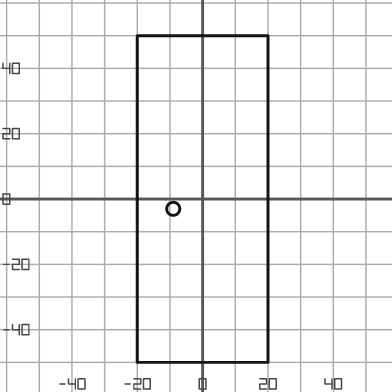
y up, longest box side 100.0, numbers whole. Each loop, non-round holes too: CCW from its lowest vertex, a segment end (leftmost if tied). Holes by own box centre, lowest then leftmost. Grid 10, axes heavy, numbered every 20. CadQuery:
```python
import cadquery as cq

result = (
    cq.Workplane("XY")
    .moveTo(-20.0, -50.0)
    .lineTo(20.0, -50.0)
    .lineTo(20.0, 50.0)
    .lineTo(-20.0, 50.0)
    .close()
    .moveTo(-9.0, -3.0)
    .circle(2.0)
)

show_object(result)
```